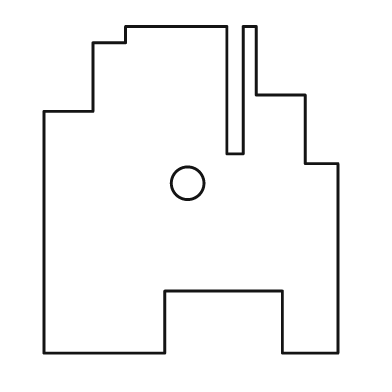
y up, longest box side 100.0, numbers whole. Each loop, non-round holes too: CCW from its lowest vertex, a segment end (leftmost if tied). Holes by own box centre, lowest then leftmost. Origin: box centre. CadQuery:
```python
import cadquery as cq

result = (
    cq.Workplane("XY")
    .moveTo(-45.0, -50.0)
    .lineTo(-8.0, -50.0)
    .lineTo(-8.0, -31.0)
    .lineTo(28.0, -31.0)
    .lineTo(28.0, -50.0)
    .lineTo(45.0, -50.0)
    .lineTo(45.0, 8.0)
    .lineTo(35.0, 8.0)
    .lineTo(35.0, 29.0)
    .lineTo(20.0, 29.0)
    .lineTo(20.0, 50.0)
    .lineTo(16.0, 50.0)
    .lineTo(16.0, 11.0)
    .lineTo(11.0, 11.0)
    .lineTo(11.0, 50.0)
    .lineTo(-20.0, 50.0)
    .lineTo(-20.0, 45.0)
    .lineTo(-30.0, 45.0)
    .lineTo(-30.0, 24.0)
    .lineTo(-45.0, 24.0)
    .close()
    .moveTo(-1.0, 2.0)
    .circle(5.0)
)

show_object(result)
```